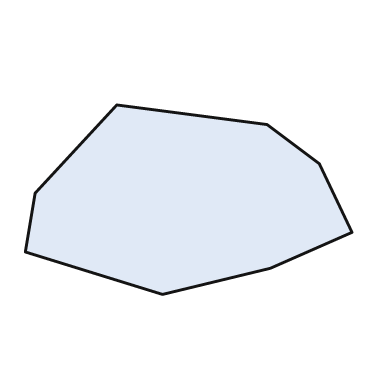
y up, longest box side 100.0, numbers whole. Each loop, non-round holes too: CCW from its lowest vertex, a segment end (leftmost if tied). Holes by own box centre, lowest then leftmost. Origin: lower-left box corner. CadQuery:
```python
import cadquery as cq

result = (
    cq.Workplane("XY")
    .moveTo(42.0, 0.0)
    .lineTo(75.0, 8.0)
    .lineTo(100.0, 19.0)
    .lineTo(90.0, 40.0)
    .lineTo(74.0, 52.0)
    .lineTo(28.0, 58.0)
    .lineTo(3.0, 31.0)
    .lineTo(0.0, 13.0)
    .close()
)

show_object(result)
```